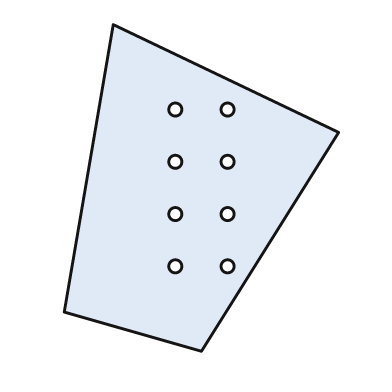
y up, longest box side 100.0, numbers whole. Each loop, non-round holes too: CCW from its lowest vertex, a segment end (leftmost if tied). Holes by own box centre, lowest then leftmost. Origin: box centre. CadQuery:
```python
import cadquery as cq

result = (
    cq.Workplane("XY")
    .moveTo(0.0, -50.0)
    .lineTo(42.0, 17.0)
    .lineTo(-27.0, 50.0)
    .lineTo(-42.0, -38.0)
    .close()
    .moveTo(-8.0, -24.0)
    .circle(2.0)
    .moveTo(8.0, -24.0)
    .circle(2.0)
    .moveTo(-8.0, -8.0)
    .circle(2.0)
    .moveTo(8.0, -8.0)
    .circle(2.0)
    .moveTo(-8.0, 8.0)
    .circle(2.0)
    .moveTo(8.0, 8.0)
    .circle(2.0)
    .moveTo(-8.0, 24.0)
    .circle(2.0)
    .moveTo(8.0, 24.0)
    .circle(2.0)
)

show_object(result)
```